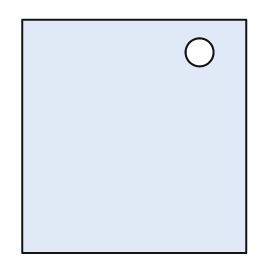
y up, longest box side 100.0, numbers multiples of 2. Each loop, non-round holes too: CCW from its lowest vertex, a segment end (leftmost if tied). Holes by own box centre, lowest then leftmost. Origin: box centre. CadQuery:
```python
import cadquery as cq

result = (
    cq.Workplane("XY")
    .moveTo(-48.0, -50.0)
    .lineTo(48.0, -50.0)
    .lineTo(48.0, 50.0)
    .lineTo(-48.0, 50.0)
    .close()
    .moveTo(28.0, 36.0)
    .circle(6.0)
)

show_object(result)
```